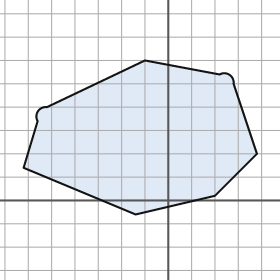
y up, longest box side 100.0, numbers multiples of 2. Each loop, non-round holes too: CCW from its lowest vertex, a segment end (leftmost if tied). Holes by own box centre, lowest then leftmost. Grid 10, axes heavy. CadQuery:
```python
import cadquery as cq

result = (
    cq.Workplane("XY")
    .moveTo(-14.0, -6.0)
    .lineTo(20.0, 2.0)
    .lineTo(38.0, 20.0)
    .lineTo(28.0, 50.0)
    .threePointArc((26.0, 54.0), (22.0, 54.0))
    .lineTo(-10.0, 60.0)
    .lineTo(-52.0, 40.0)
    .threePointArc((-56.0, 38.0), (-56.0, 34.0))
    .lineTo(-62.0, 14.0)
    .close()
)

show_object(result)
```